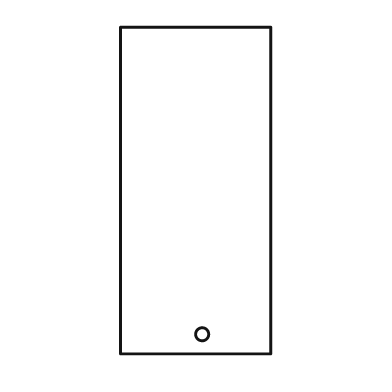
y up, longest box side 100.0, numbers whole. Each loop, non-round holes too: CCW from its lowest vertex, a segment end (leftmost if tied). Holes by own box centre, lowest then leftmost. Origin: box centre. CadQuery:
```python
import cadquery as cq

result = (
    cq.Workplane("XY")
    .moveTo(-23.0, -50.0)
    .lineTo(23.0, -50.0)
    .lineTo(23.0, 50.0)
    .lineTo(-23.0, 50.0)
    .close()
    .moveTo(2.0, -44.0)
    .circle(2.0)
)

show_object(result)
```